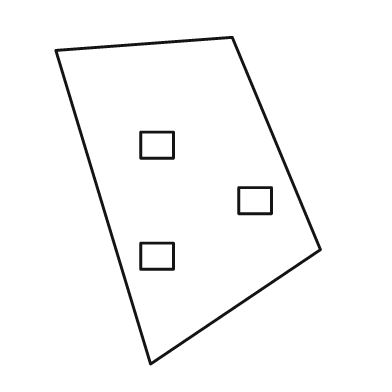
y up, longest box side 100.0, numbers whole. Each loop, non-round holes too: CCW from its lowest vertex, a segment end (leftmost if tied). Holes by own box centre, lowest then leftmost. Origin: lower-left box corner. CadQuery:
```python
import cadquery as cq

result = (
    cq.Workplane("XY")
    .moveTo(29.0, 0.0)
    .lineTo(81.0, 35.0)
    .lineTo(54.0, 100.0)
    .lineTo(0.0, 96.0)
    .close()
    .moveTo(26.0, 29.0)
    .lineTo(36.0, 29.0)
    .lineTo(36.0, 37.0)
    .lineTo(26.0, 37.0)
    .close()
    .moveTo(56.0, 46.0)
    .lineTo(66.0, 46.0)
    .lineTo(66.0, 54.0)
    .lineTo(56.0, 54.0)
    .close()
    .moveTo(26.0, 63.0)
    .lineTo(36.0, 63.0)
    .lineTo(36.0, 71.0)
    .lineTo(26.0, 71.0)
    .close()
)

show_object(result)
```